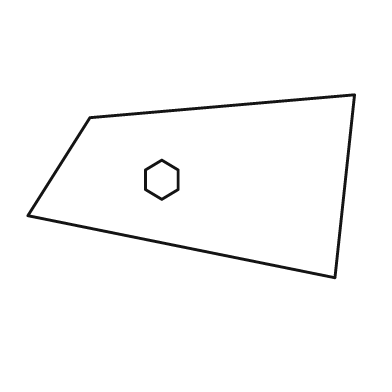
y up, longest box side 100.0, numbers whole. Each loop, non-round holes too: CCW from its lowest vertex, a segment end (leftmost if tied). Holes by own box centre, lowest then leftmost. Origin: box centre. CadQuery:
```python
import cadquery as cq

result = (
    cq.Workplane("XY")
    .moveTo(44.0, -28.0)
    .lineTo(50.0, 28.0)
    .lineTo(-31.0, 21.0)
    .lineTo(-50.0, -9.0)
    .close()
    .moveTo(-9.0, -4.0)
    .lineTo(-4.0, -1.0)
    .lineTo(-4.0, 5.0)
    .lineTo(-9.0, 8.0)
    .lineTo(-14.0, 5.0)
    .lineTo(-14.0, -1.0)
    .close()
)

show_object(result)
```